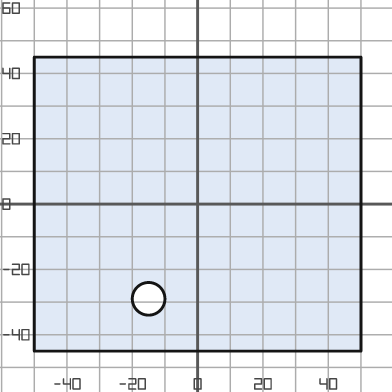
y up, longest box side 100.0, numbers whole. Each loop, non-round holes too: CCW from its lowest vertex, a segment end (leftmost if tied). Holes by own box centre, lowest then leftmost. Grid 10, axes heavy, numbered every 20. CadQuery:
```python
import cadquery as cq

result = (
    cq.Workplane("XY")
    .moveTo(-50.0, -45.0)
    .lineTo(50.0, -45.0)
    .lineTo(50.0, 45.0)
    .lineTo(-50.0, 45.0)
    .close()
    .moveTo(-15.0, -29.0)
    .circle(5.0)
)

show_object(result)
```